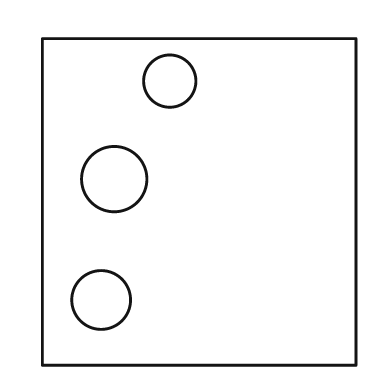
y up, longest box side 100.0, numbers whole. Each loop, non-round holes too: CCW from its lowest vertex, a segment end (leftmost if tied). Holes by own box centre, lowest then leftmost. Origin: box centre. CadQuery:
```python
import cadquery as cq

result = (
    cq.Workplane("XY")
    .moveTo(-48.0, -50.0)
    .lineTo(48.0, -50.0)
    .lineTo(48.0, 50.0)
    .lineTo(-48.0, 50.0)
    .close()
    .moveTo(-30.0, -30.0)
    .circle(9.0)
    .moveTo(-26.0, 7.0)
    .circle(10.0)
    .moveTo(-9.0, 37.0)
    .circle(8.0)
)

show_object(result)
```